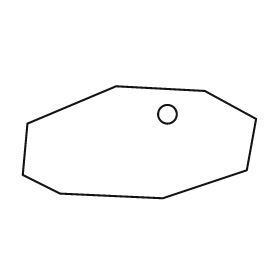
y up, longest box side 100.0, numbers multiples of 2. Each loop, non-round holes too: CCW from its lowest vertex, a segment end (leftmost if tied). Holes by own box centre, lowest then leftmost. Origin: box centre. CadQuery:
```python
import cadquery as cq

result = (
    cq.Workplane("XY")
    .moveTo(10.0, -24.0)
    .lineTo(46.0, -12.0)
    .lineTo(50.0, 10.0)
    .lineTo(28.0, 22.0)
    .lineTo(-10.0, 24.0)
    .lineTo(-48.0, 8.0)
    .lineTo(-50.0, -14.0)
    .lineTo(-34.0, -22.0)
    .close()
    .moveTo(12.0, 12.0)
    .circle(4.0)
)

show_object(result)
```